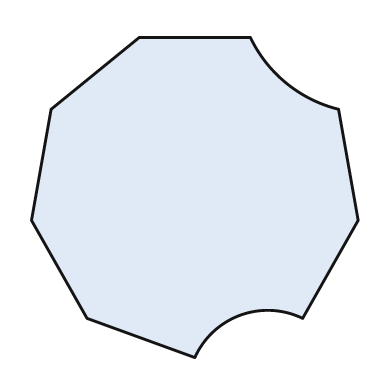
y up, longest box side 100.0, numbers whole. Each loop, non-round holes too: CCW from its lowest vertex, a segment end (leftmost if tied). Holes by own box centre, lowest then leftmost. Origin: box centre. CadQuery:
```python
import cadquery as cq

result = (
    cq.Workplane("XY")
    .moveTo(0.0, -49.0)
    .threePointArc((14.0, -36.0), (33.0, -37.0))
    .lineTo(50.0, -7.0)
    .lineTo(44.0, 27.0)
    .threePointArc((28.0, 35.0), (17.0, 49.0))
    .lineTo(-17.0, 49.0)
    .lineTo(-44.0, 27.0)
    .lineTo(-50.0, -7.0)
    .lineTo(-33.0, -37.0)
    .close()
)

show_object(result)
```